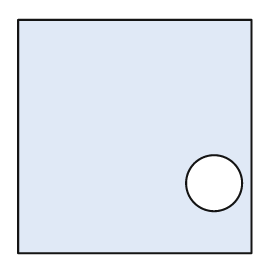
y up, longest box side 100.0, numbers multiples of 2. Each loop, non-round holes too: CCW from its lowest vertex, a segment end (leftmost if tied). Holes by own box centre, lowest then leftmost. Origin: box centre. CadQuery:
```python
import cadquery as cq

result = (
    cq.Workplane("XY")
    .moveTo(-50.0, -50.0)
    .lineTo(50.0, -50.0)
    .lineTo(50.0, 50.0)
    .lineTo(-50.0, 50.0)
    .close()
    .moveTo(34.0, -20.0)
    .circle(12.0)
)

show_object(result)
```